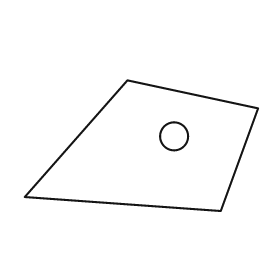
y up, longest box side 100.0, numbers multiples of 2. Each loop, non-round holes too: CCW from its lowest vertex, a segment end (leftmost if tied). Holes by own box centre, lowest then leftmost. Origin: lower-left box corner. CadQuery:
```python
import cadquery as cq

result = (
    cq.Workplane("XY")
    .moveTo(84.0, 0.0)
    .lineTo(100.0, 44.0)
    .lineTo(44.0, 56.0)
    .lineTo(0.0, 6.0)
    .close()
    .moveTo(64.0, 32.0)
    .circle(6.0)
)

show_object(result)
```